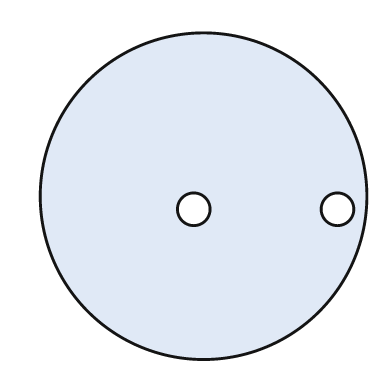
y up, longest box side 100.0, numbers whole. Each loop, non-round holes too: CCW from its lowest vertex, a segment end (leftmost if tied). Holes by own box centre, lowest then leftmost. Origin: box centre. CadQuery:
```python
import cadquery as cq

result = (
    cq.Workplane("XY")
    .moveTo(0.0, 0.0)
    .circle(50.0)
    .moveTo(-3.0, -4.0)
    .circle(5.0)
    .moveTo(41.0, -4.0)
    .circle(5.0)
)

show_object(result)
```